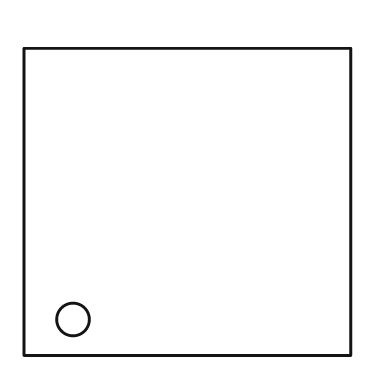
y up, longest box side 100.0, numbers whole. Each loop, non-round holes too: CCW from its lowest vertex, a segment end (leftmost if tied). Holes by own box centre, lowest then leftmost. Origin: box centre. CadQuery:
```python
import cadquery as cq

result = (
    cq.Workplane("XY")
    .moveTo(-50.0, -47.0)
    .lineTo(50.0, -47.0)
    .lineTo(50.0, 47.0)
    .lineTo(-50.0, 47.0)
    .close()
    .moveTo(-35.0, -36.0)
    .circle(5.0)
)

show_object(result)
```